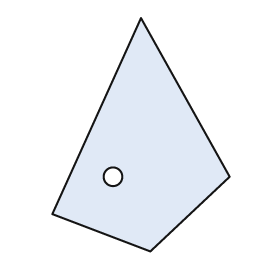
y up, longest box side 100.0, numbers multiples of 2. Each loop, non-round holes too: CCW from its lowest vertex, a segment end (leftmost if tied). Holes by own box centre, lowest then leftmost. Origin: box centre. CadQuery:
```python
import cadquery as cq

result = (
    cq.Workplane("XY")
    .moveTo(4.0, -50.0)
    .lineTo(38.0, -18.0)
    .lineTo(0.0, 50.0)
    .lineTo(-38.0, -34.0)
    .close()
    .moveTo(-12.0, -18.0)
    .circle(4.0)
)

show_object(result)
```